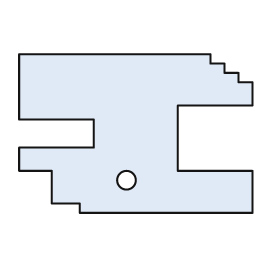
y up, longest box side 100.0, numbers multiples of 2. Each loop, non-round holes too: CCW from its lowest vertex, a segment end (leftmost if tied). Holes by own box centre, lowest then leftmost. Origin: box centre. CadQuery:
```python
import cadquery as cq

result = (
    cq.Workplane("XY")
    .moveTo(-24.0, -34.0)
    .lineTo(50.0, -34.0)
    .lineTo(50.0, -16.0)
    .lineTo(18.0, -16.0)
    .lineTo(18.0, 12.0)
    .lineTo(50.0, 12.0)
    .lineTo(50.0, 22.0)
    .lineTo(44.0, 22.0)
    .lineTo(44.0, 26.0)
    .lineTo(38.0, 26.0)
    .lineTo(38.0, 30.0)
    .lineTo(32.0, 30.0)
    .lineTo(32.0, 34.0)
    .lineTo(-50.0, 34.0)
    .lineTo(-50.0, 6.0)
    .lineTo(-18.0, 6.0)
    .lineTo(-18.0, -6.0)
    .lineTo(-50.0, -6.0)
    .lineTo(-50.0, -16.0)
    .lineTo(-36.0, -16.0)
    .lineTo(-36.0, -30.0)
    .lineTo(-24.0, -30.0)
    .close()
    .moveTo(-4.0, -20.0)
    .circle(4.0)
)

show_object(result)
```